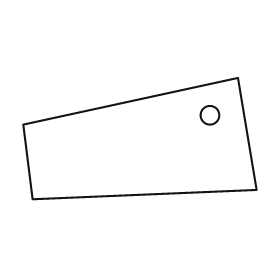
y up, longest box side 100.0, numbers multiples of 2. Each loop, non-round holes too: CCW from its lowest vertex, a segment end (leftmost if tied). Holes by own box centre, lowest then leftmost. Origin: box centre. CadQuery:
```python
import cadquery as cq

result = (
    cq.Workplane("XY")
    .moveTo(-46.0, -26.0)
    .lineTo(50.0, -22.0)
    .lineTo(42.0, 26.0)
    .lineTo(-50.0, 6.0)
    .close()
    .moveTo(30.0, 10.0)
    .circle(4.0)
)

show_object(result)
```